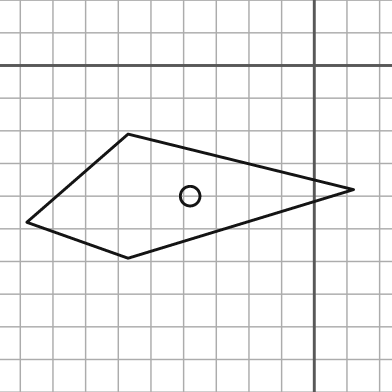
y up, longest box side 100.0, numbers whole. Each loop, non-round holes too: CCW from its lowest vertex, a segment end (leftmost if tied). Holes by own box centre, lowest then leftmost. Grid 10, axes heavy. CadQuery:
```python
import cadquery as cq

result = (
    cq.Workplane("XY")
    .moveTo(-57.0, -59.0)
    .lineTo(12.0, -38.0)
    .lineTo(-57.0, -21.0)
    .lineTo(-88.0, -48.0)
    .close()
    .moveTo(-38.0, -40.0)
    .circle(3.0)
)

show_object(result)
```